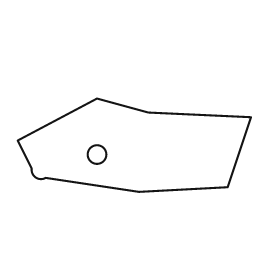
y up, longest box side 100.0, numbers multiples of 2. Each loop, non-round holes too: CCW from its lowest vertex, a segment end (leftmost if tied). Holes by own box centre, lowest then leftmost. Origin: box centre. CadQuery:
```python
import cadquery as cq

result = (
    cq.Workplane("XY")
    .moveTo(2.0, -20.0)
    .lineTo(40.0, -18.0)
    .lineTo(50.0, 12.0)
    .lineTo(6.0, 14.0)
    .lineTo(-16.0, 20.0)
    .lineTo(-50.0, 2.0)
    .lineTo(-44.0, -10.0)
    .threePointArc((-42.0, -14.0), (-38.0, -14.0))
    .close()
    .moveTo(-16.0, -4.0)
    .circle(4.0)
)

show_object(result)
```